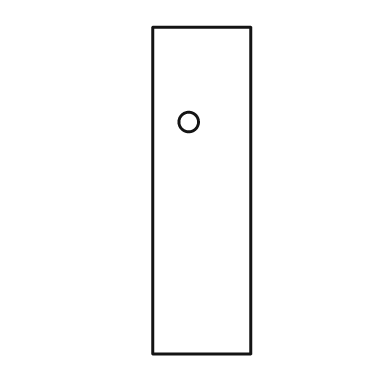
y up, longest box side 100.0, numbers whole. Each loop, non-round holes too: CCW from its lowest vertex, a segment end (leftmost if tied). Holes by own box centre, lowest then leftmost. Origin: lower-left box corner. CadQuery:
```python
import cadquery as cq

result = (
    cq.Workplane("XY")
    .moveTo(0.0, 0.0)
    .lineTo(30.0, 0.0)
    .lineTo(30.0, 100.0)
    .lineTo(0.0, 100.0)
    .close()
    .moveTo(11.0, 71.0)
    .circle(3.0)
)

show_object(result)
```